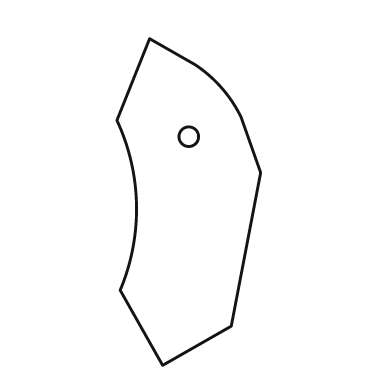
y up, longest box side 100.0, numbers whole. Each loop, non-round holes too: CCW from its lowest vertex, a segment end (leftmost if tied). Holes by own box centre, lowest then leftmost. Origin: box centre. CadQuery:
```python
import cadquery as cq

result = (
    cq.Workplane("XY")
    .moveTo(-8.0, -50.0)
    .lineTo(13.0, -38.0)
    .lineTo(22.0, 9.0)
    .lineTo(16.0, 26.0)
    .threePointArc((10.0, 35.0), (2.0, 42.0))
    .lineTo(-12.0, 50.0)
    .lineTo(-22.0, 25.0)
    .threePointArc((-16.0, -1.0), (-21.0, -27.0))
    .close()
    .moveTo(0.0, 20.0)
    .circle(3.0)
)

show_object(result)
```